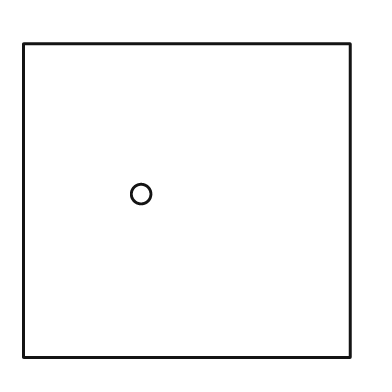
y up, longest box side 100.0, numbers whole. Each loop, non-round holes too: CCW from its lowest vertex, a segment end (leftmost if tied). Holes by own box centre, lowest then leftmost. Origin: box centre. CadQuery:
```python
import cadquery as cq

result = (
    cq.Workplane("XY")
    .moveTo(-50.0, -48.0)
    .lineTo(50.0, -48.0)
    .lineTo(50.0, 48.0)
    .lineTo(-50.0, 48.0)
    .close()
    .moveTo(-14.0, 2.0)
    .circle(3.0)
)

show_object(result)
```